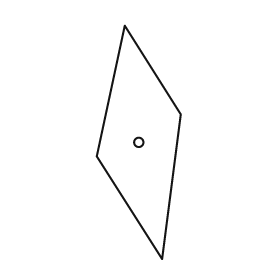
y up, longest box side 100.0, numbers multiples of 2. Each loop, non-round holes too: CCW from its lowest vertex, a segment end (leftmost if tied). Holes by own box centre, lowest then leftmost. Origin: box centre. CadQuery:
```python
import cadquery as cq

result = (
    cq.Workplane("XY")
    .moveTo(10.0, -50.0)
    .lineTo(18.0, 12.0)
    .lineTo(-6.0, 50.0)
    .lineTo(-18.0, -6.0)
    .close()
    .moveTo(0.0, 0.0)
    .circle(2.0)
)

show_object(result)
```